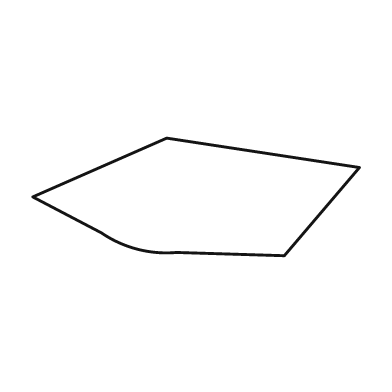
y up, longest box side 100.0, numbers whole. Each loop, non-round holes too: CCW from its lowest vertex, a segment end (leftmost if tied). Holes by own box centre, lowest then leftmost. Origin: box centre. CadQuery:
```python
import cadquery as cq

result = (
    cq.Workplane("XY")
    .moveTo(27.0, -18.0)
    .lineTo(50.0, 9.0)
    .lineTo(-9.0, 18.0)
    .lineTo(-50.0, 0.0)
    .lineTo(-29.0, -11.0)
    .threePointArc((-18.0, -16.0), (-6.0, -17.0))
    .close()
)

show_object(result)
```